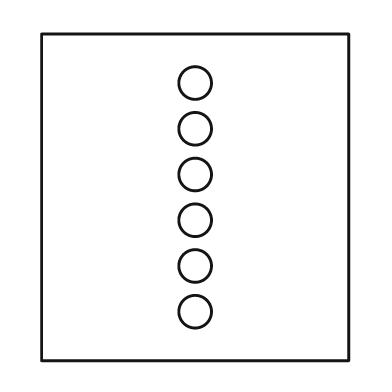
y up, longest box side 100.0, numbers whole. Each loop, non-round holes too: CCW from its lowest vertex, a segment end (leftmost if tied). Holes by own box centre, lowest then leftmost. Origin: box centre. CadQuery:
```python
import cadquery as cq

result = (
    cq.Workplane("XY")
    .moveTo(-47.0, -50.0)
    .lineTo(47.0, -50.0)
    .lineTo(47.0, 50.0)
    .lineTo(-47.0, 50.0)
    .close()
    .moveTo(0.0, -35.0)
    .circle(5.0)
    .moveTo(0.0, -21.0)
    .circle(5.0)
    .moveTo(0.0, -7.0)
    .circle(5.0)
    .moveTo(0.0, 7.0)
    .circle(5.0)
    .moveTo(0.0, 21.0)
    .circle(5.0)
    .moveTo(0.0, 35.0)
    .circle(5.0)
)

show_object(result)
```